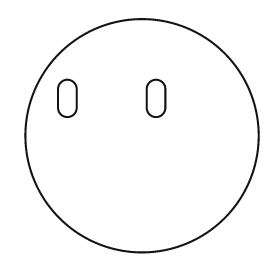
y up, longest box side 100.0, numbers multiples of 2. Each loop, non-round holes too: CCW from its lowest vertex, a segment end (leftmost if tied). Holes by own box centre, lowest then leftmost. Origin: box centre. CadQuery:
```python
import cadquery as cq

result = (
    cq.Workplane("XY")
    .moveTo(0.0, 0.0)
    .circle(50.0)
    .moveTo(-36.0, 12.0)
    .threePointArc((-32.0, 8.0), (-28.0, 12.0))
    .lineTo(-28.0, 20.0)
    .threePointArc((-32.0, 24.0), (-36.0, 20.0))
    .close()
    .moveTo(2.0, 12.0)
    .threePointArc((6.0, 8.0), (10.0, 12.0))
    .lineTo(10.0, 20.0)
    .threePointArc((6.0, 24.0), (2.0, 20.0))
    .close()
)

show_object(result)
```